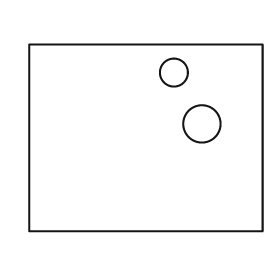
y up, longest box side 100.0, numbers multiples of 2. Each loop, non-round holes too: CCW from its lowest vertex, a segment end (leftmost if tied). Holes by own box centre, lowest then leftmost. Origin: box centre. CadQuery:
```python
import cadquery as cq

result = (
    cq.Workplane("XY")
    .moveTo(-50.0, -40.0)
    .lineTo(50.0, -40.0)
    .lineTo(50.0, 40.0)
    .lineTo(-50.0, 40.0)
    .close()
    .moveTo(24.0, 6.0)
    .circle(8.0)
    .moveTo(12.0, 28.0)
    .circle(6.0)
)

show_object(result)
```